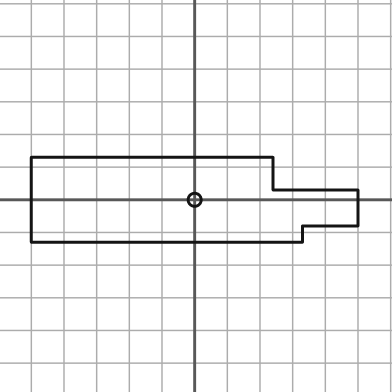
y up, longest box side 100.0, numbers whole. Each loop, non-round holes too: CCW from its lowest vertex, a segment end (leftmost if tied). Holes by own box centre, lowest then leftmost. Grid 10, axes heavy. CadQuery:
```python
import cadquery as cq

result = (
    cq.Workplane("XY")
    .moveTo(-50.0, -13.0)
    .lineTo(33.0, -13.0)
    .lineTo(33.0, -8.0)
    .lineTo(50.0, -8.0)
    .lineTo(50.0, 3.0)
    .lineTo(24.0, 3.0)
    .lineTo(24.0, 13.0)
    .lineTo(-50.0, 13.0)
    .close()
    .moveTo(0.0, 0.0)
    .circle(2.0)
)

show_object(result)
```